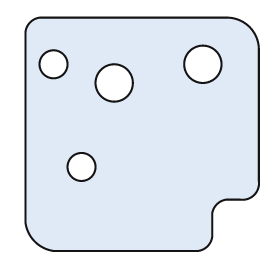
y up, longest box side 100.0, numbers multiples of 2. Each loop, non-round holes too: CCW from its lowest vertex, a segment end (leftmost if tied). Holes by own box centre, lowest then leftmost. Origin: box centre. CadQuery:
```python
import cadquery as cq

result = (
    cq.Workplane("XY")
    .moveTo(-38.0, -50.0)
    .lineTo(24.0, -50.0)
    .threePointArc((28.0, -48.0), (30.0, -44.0))
    .lineTo(30.0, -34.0)
    .threePointArc((32.0, -30.0), (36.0, -28.0))
    .lineTo(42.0, -28.0)
    .threePointArc((48.0, -26.0), (50.0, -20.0))
    .lineTo(50.0, 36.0)
    .threePointArc((46.0, 46.0), (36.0, 50.0))
    .lineTo(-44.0, 50.0)
    .threePointArc((-48.0, 48.0), (-50.0, 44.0))
    .lineTo(-50.0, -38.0)
    .threePointArc((-46.0, -46.0), (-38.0, -50.0))
    .close()
    .moveTo(-26.0, -14.0)
    .circle(6.0)
    .moveTo(-12.0, 22.0)
    .circle(8.0)
    .moveTo(-38.0, 30.0)
    .circle(6.0)
    .moveTo(26.0, 30.0)
    .circle(8.0)
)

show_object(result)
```